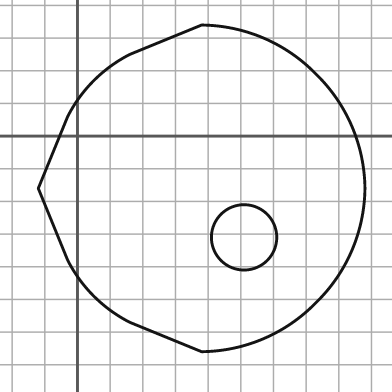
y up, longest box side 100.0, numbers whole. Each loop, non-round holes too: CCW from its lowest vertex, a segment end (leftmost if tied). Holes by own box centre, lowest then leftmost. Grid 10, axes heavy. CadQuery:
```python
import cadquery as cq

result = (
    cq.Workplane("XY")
    .moveTo(38.0, -66.0)
    .threePointArc((57.0, -62.0), (73.0, -51.0))
    .threePointArc((84.0, -35.0), (88.0, -16.0))
    .threePointArc((84.0, 3.0), (73.0, 19.0))
    .threePointArc((57.0, 30.0), (38.0, 34.0))
    .lineTo(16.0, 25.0)
    .threePointArc((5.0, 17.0), (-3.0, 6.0))
    .lineTo(-12.0, -16.0)
    .lineTo(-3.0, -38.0)
    .threePointArc((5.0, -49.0), (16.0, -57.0))
    .close()
    .moveTo(51.0, -31.0)
    .circle(10.0)
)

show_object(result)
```